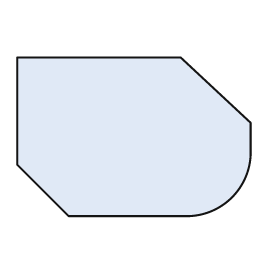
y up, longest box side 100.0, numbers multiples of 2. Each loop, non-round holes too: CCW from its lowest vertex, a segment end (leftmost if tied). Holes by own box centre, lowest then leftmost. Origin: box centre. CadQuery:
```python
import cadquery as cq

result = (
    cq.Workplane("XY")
    .moveTo(-28.0, -34.0)
    .lineTo(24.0, -34.0)
    .threePointArc((42.0, -26.0), (50.0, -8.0))
    .lineTo(50.0, 6.0)
    .lineTo(20.0, 34.0)
    .lineTo(-50.0, 34.0)
    .lineTo(-50.0, -12.0)
    .close()
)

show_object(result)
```